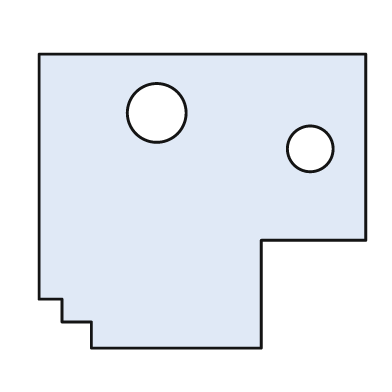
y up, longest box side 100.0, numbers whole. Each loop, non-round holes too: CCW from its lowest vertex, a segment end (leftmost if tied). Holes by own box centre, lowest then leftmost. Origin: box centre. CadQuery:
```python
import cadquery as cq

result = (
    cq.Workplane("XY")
    .moveTo(-34.0, -45.0)
    .lineTo(18.0, -45.0)
    .lineTo(18.0, -12.0)
    .lineTo(50.0, -12.0)
    .lineTo(50.0, 45.0)
    .lineTo(-50.0, 45.0)
    .lineTo(-50.0, -30.0)
    .lineTo(-43.0, -30.0)
    .lineTo(-43.0, -37.0)
    .lineTo(-34.0, -37.0)
    .close()
    .moveTo(33.0, 16.0)
    .circle(7.0)
    .moveTo(-14.0, 27.0)
    .circle(9.0)
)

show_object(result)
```